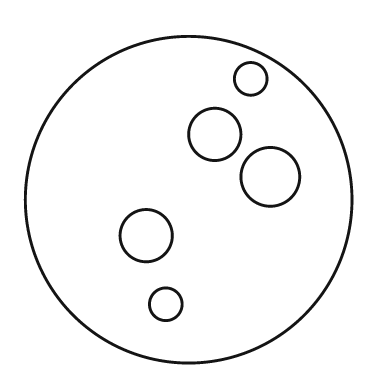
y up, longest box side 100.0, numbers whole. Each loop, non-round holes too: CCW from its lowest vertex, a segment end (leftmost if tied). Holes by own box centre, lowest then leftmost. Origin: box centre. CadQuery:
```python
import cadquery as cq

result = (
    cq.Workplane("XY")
    .moveTo(0.0, 0.0)
    .circle(50.0)
    .moveTo(-7.0, -32.0)
    .circle(5.0)
    .moveTo(-13.0, -11.0)
    .circle(8.0)
    .moveTo(25.0, 7.0)
    .circle(9.0)
    .moveTo(8.0, 20.0)
    .circle(8.0)
    .moveTo(19.0, 37.0)
    .circle(5.0)
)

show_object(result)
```